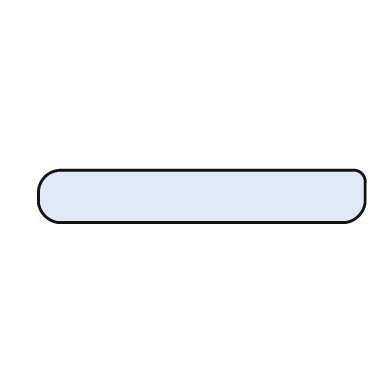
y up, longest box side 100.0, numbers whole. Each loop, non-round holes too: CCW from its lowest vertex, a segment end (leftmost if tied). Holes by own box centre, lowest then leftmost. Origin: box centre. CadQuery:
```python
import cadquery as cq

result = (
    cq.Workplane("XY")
    .moveTo(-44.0, -8.0)
    .lineTo(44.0, -8.0)
    .threePointArc((48.0, -6.0), (50.0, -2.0))
    .lineTo(50.0, 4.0)
    .threePointArc((49.0, 7.0), (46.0, 8.0))
    .lineTo(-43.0, 8.0)
    .threePointArc((-48.0, 6.0), (-50.0, 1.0))
    .lineTo(-50.0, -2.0)
    .threePointArc((-48.0, -6.0), (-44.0, -8.0))
    .close()
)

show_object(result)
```